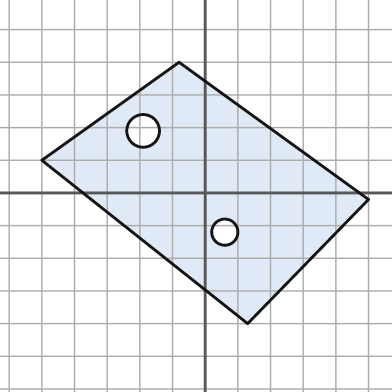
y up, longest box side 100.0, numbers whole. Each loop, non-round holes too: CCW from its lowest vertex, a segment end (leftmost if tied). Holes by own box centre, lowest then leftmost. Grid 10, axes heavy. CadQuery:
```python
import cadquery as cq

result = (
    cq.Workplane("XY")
    .moveTo(13.0, -40.0)
    .lineTo(50.0, -2.0)
    .lineTo(-8.0, 40.0)
    .lineTo(-50.0, 10.0)
    .close()
    .moveTo(6.0, -12.0)
    .circle(4.0)
    .moveTo(-19.0, 19.0)
    .circle(5.0)
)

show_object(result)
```